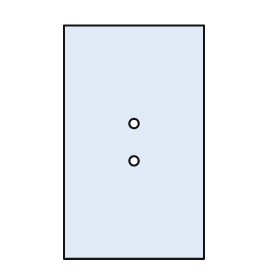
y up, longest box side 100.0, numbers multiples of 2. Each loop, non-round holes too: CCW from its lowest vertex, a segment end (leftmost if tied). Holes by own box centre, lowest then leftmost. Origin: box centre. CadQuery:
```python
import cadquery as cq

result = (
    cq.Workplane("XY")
    .moveTo(-30.0, -50.0)
    .lineTo(30.0, -50.0)
    .lineTo(30.0, 50.0)
    .lineTo(-30.0, 50.0)
    .close()
    .moveTo(0.0, -8.0)
    .circle(2.0)
    .moveTo(0.0, 8.0)
    .circle(2.0)
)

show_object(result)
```